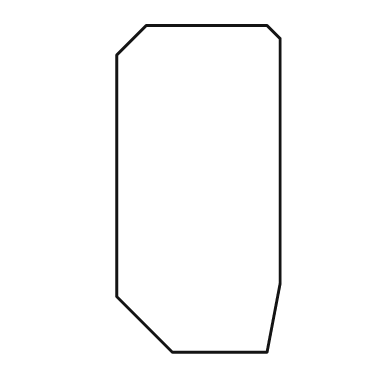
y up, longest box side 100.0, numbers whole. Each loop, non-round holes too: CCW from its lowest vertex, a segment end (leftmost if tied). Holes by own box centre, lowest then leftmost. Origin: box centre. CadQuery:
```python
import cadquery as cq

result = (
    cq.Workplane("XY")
    .moveTo(-8.0, -50.0)
    .lineTo(21.0, -50.0)
    .lineTo(25.0, -29.0)
    .lineTo(25.0, 46.0)
    .lineTo(21.0, 50.0)
    .lineTo(-16.0, 50.0)
    .lineTo(-25.0, 41.0)
    .lineTo(-25.0, -33.0)
    .close()
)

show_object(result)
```